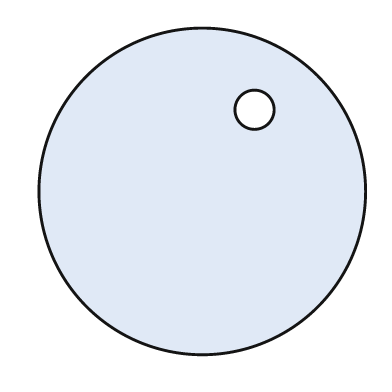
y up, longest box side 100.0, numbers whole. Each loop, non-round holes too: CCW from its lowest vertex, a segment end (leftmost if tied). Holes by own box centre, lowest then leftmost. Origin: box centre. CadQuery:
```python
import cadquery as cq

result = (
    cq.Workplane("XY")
    .moveTo(0.0, 0.0)
    .circle(50.0)
    .moveTo(16.0, 25.0)
    .circle(6.0)
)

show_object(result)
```